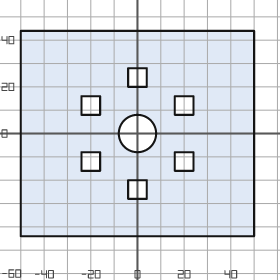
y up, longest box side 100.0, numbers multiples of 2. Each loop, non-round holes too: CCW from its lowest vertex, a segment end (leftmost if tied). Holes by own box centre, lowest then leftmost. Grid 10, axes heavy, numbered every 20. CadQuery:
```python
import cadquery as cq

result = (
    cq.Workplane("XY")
    .moveTo(-50.0, -44.0)
    .lineTo(50.0, -44.0)
    .lineTo(50.0, 44.0)
    .lineTo(-50.0, 44.0)
    .close()
    .moveTo(-4.0, -28.0)
    .lineTo(4.0, -28.0)
    .lineTo(4.0, -20.0)
    .lineTo(-4.0, -20.0)
    .close()
    .moveTo(-24.0, -16.0)
    .lineTo(-16.0, -16.0)
    .lineTo(-16.0, -8.0)
    .lineTo(-24.0, -8.0)
    .close()
    .moveTo(16.0, -16.0)
    .lineTo(24.0, -16.0)
    .lineTo(24.0, -8.0)
    .lineTo(16.0, -8.0)
    .close()
    .moveTo(0.0, 0.0)
    .circle(8.0)
    .moveTo(-24.0, 8.0)
    .lineTo(-16.0, 8.0)
    .lineTo(-16.0, 16.0)
    .lineTo(-24.0, 16.0)
    .close()
    .moveTo(16.0, 8.0)
    .lineTo(24.0, 8.0)
    .lineTo(24.0, 16.0)
    .lineTo(16.0, 16.0)
    .close()
    .moveTo(-4.0, 20.0)
    .lineTo(4.0, 20.0)
    .lineTo(4.0, 28.0)
    .lineTo(-4.0, 28.0)
    .close()
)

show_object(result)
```